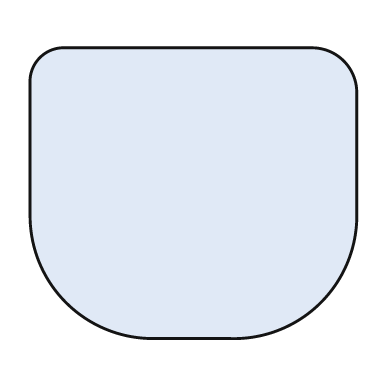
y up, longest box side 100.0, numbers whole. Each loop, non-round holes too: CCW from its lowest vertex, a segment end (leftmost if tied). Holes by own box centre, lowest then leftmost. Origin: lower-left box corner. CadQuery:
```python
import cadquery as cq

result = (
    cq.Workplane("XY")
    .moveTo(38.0, 0.0)
    .lineTo(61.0, 0.0)
    .threePointArc((89.0, 11.0), (100.0, 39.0))
    .lineTo(100.0, 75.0)
    .threePointArc((96.0, 85.0), (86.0, 89.0))
    .lineTo(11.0, 89.0)
    .threePointArc((3.0, 86.0), (0.0, 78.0))
    .lineTo(0.0, 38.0)
    .threePointArc((11.0, 11.0), (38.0, 0.0))
    .close()
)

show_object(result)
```